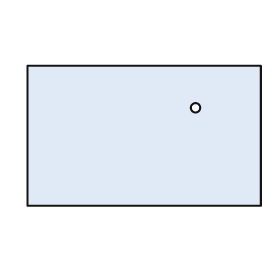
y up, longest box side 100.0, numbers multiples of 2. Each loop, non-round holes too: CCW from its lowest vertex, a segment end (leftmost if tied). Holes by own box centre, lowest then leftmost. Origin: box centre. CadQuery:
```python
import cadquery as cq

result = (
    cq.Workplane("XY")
    .moveTo(-50.0, -30.0)
    .lineTo(50.0, -30.0)
    .lineTo(50.0, 30.0)
    .lineTo(-50.0, 30.0)
    .close()
    .moveTo(22.0, 12.0)
    .circle(2.0)
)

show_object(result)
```